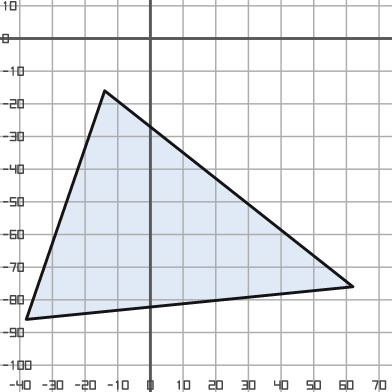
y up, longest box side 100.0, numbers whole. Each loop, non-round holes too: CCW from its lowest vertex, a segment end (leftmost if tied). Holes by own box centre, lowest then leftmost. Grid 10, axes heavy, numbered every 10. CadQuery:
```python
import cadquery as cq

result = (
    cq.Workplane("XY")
    .moveTo(-38.0, -86.0)
    .lineTo(62.0, -76.0)
    .lineTo(-14.0, -16.0)
    .close()
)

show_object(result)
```